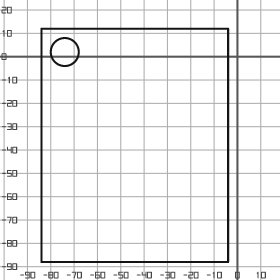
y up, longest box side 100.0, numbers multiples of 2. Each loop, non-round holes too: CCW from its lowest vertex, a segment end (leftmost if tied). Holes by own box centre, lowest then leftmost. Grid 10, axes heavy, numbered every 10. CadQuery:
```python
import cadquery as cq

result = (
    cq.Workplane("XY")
    .moveTo(-84.0, -88.0)
    .lineTo(-4.0, -88.0)
    .lineTo(-4.0, 12.0)
    .lineTo(-84.0, 12.0)
    .close()
    .moveTo(-74.0, 2.0)
    .circle(6.0)
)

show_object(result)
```